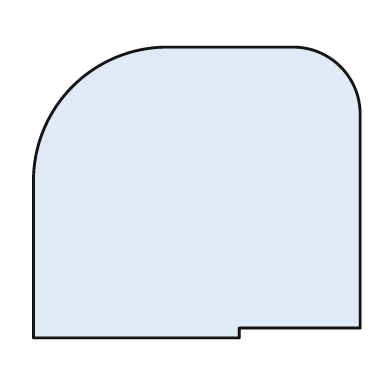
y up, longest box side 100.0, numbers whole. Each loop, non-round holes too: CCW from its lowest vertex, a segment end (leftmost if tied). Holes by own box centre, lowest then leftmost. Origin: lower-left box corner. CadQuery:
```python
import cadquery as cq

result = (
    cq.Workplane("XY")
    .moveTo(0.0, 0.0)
    .lineTo(63.0, 0.0)
    .lineTo(63.0, 3.0)
    .lineTo(100.0, 3.0)
    .lineTo(100.0, 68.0)
    .threePointArc((94.0, 83.0), (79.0, 89.0))
    .lineTo(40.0, 89.0)
    .threePointArc((12.0, 77.0), (0.0, 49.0))
    .close()
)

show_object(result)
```